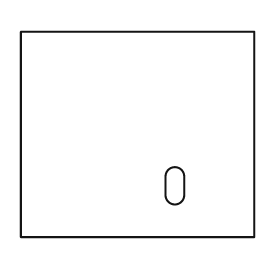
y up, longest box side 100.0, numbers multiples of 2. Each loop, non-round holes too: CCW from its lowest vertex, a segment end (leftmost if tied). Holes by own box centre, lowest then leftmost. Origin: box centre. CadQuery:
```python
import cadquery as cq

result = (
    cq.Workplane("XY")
    .moveTo(-50.0, -44.0)
    .lineTo(50.0, -44.0)
    .lineTo(50.0, 44.0)
    .lineTo(-50.0, 44.0)
    .close()
    .moveTo(12.0, -26.0)
    .threePointArc((16.0, -30.0), (20.0, -26.0))
    .lineTo(20.0, -18.0)
    .threePointArc((16.0, -14.0), (12.0, -18.0))
    .close()
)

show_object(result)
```